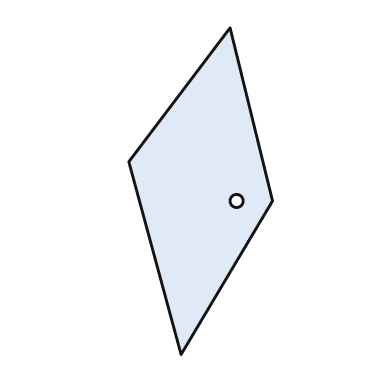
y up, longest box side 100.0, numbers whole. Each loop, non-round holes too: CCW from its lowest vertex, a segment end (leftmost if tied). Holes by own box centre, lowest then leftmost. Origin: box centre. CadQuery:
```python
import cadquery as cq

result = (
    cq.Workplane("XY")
    .moveTo(-6.0, -50.0)
    .lineTo(22.0, -3.0)
    .lineTo(9.0, 50.0)
    .lineTo(-22.0, 9.0)
    .close()
    .moveTo(11.0, -3.0)
    .circle(2.0)
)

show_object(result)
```